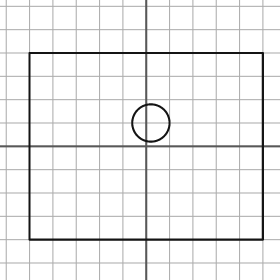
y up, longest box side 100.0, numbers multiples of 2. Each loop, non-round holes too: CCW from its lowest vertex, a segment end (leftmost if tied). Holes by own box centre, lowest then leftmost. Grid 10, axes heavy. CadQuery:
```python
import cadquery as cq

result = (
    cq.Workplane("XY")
    .moveTo(-50.0, -40.0)
    .lineTo(50.0, -40.0)
    .lineTo(50.0, 40.0)
    .lineTo(-50.0, 40.0)
    .close()
    .moveTo(2.0, 10.0)
    .circle(8.0)
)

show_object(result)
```